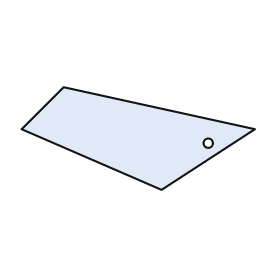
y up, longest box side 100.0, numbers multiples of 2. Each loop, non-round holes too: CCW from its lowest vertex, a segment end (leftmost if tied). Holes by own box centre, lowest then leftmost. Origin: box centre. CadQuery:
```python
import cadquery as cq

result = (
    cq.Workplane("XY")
    .moveTo(10.0, -22.0)
    .lineTo(50.0, 4.0)
    .lineTo(-32.0, 22.0)
    .lineTo(-50.0, 4.0)
    .close()
    .moveTo(30.0, -2.0)
    .circle(2.0)
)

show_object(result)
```